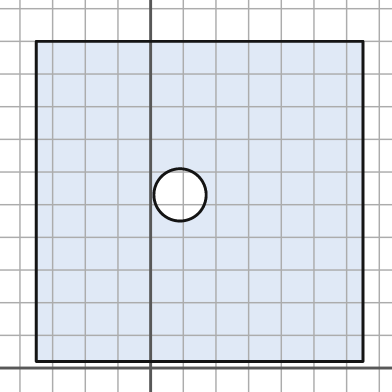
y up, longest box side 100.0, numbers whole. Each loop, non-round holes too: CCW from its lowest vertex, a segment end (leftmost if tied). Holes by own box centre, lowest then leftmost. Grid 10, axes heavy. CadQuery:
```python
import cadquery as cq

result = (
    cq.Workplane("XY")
    .moveTo(-35.0, 2.0)
    .lineTo(65.0, 2.0)
    .lineTo(65.0, 100.0)
    .lineTo(-35.0, 100.0)
    .close()
    .moveTo(9.0, 53.0)
    .circle(8.0)
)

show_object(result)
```